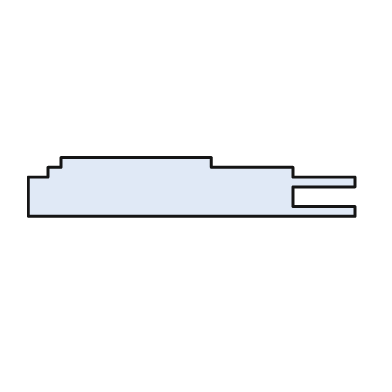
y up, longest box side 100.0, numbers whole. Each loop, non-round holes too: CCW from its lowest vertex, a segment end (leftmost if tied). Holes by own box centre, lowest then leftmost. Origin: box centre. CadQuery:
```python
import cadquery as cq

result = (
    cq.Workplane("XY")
    .moveTo(-50.0, -9.0)
    .lineTo(50.0, -9.0)
    .lineTo(50.0, -6.0)
    .lineTo(31.0, -6.0)
    .lineTo(31.0, 0.0)
    .lineTo(50.0, 0.0)
    .lineTo(50.0, 3.0)
    .lineTo(31.0, 3.0)
    .lineTo(31.0, 6.0)
    .lineTo(6.0, 6.0)
    .lineTo(6.0, 9.0)
    .lineTo(-40.0, 9.0)
    .lineTo(-40.0, 6.0)
    .lineTo(-44.0, 6.0)
    .lineTo(-44.0, 3.0)
    .lineTo(-50.0, 3.0)
    .close()
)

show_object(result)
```